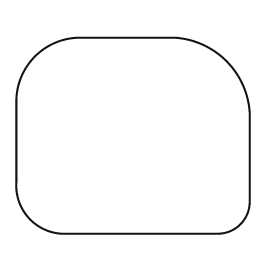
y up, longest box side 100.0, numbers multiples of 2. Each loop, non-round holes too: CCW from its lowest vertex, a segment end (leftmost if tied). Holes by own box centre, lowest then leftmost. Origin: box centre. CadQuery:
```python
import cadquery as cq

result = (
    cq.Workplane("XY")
    .moveTo(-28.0, -42.0)
    .lineTo(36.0, -42.0)
    .threePointArc((46.0, -38.0), (50.0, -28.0))
    .lineTo(50.0, 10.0)
    .threePointArc((40.0, 32.0), (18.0, 42.0))
    .lineTo(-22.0, 42.0)
    .threePointArc((-42.0, 34.0), (-50.0, 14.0))
    .lineTo(-50.0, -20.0)
    .threePointArc((-44.0, -36.0), (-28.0, -42.0))
    .close()
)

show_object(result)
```